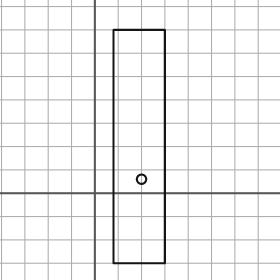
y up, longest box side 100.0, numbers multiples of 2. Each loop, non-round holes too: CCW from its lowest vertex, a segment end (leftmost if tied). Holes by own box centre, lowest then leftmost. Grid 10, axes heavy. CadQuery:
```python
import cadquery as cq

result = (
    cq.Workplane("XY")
    .moveTo(8.0, -30.0)
    .lineTo(30.0, -30.0)
    .lineTo(30.0, 70.0)
    .lineTo(8.0, 70.0)
    .close()
    .moveTo(20.0, 6.0)
    .circle(2.0)
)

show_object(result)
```